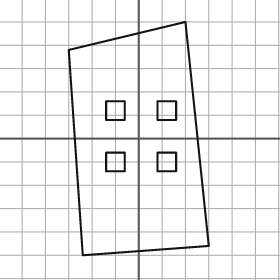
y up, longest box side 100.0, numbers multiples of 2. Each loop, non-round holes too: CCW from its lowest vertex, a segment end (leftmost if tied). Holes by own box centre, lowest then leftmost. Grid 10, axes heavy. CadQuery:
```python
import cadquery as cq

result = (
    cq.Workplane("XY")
    .moveTo(-24.0, -50.0)
    .lineTo(30.0, -46.0)
    .lineTo(20.0, 50.0)
    .lineTo(-30.0, 38.0)
    .close()
    .moveTo(-14.0, -14.0)
    .lineTo(-6.0, -14.0)
    .lineTo(-6.0, -6.0)
    .lineTo(-14.0, -6.0)
    .close()
    .moveTo(8.0, -14.0)
    .lineTo(16.0, -14.0)
    .lineTo(16.0, -6.0)
    .lineTo(8.0, -6.0)
    .close()
    .moveTo(-14.0, 8.0)
    .lineTo(-6.0, 8.0)
    .lineTo(-6.0, 16.0)
    .lineTo(-14.0, 16.0)
    .close()
    .moveTo(8.0, 8.0)
    .lineTo(16.0, 8.0)
    .lineTo(16.0, 16.0)
    .lineTo(8.0, 16.0)
    .close()
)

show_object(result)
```